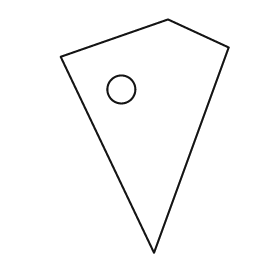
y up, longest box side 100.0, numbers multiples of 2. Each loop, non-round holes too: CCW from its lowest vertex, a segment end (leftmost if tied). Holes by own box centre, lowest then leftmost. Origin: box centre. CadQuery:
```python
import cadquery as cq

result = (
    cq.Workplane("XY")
    .moveTo(4.0, -50.0)
    .lineTo(36.0, 38.0)
    .lineTo(10.0, 50.0)
    .lineTo(-36.0, 34.0)
    .close()
    .moveTo(-10.0, 20.0)
    .circle(6.0)
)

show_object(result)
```